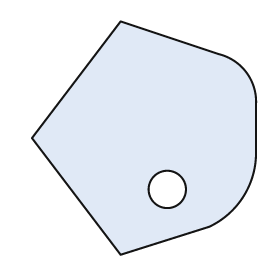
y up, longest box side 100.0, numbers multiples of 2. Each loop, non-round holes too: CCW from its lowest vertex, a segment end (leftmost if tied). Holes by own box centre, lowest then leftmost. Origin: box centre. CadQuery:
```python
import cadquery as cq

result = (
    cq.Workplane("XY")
    .moveTo(-10.0, -50.0)
    .lineTo(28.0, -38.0)
    .threePointArc((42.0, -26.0), (48.0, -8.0))
    .lineTo(48.0, 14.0)
    .threePointArc((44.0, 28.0), (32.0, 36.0))
    .lineTo(-10.0, 50.0)
    .lineTo(-48.0, 0.0)
    .close()
    .moveTo(10.0, -22.0)
    .circle(8.0)
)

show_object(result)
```